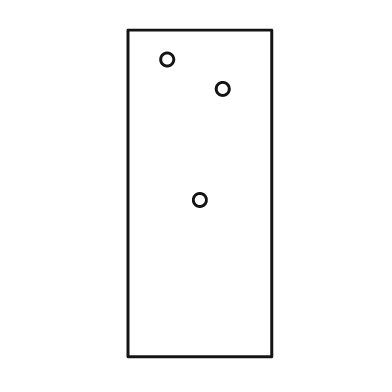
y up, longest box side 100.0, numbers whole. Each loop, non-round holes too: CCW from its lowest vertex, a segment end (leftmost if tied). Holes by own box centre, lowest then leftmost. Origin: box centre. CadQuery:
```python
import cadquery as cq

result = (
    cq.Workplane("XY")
    .moveTo(-22.0, -50.0)
    .lineTo(22.0, -50.0)
    .lineTo(22.0, 50.0)
    .lineTo(-22.0, 50.0)
    .close()
    .moveTo(0.0, -2.0)
    .circle(2.0)
    .moveTo(7.0, 32.0)
    .circle(2.0)
    .moveTo(-10.0, 41.0)
    .circle(2.0)
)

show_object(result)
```